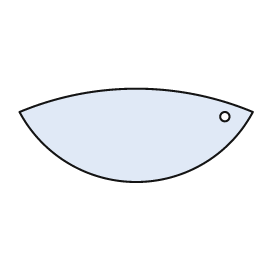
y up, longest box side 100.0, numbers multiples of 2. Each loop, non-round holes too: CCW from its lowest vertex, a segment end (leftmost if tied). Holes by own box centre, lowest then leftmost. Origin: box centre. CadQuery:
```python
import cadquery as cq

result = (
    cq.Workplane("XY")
    .moveTo(-50.0, 10.0)
    .threePointArc((0.0, -20.0), (50.0, 10.0))
    .threePointArc((0.0, 20.0), (-50.0, 10.0))
    .close()
    .moveTo(38.0, 8.0)
    .circle(2.0)
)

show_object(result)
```